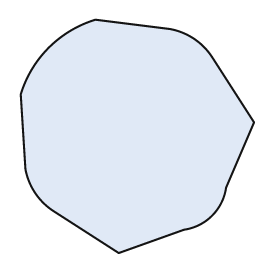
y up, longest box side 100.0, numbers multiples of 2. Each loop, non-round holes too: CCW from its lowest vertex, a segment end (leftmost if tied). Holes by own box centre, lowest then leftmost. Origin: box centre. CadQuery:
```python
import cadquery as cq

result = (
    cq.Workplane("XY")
    .moveTo(-8.0, -50.0)
    .lineTo(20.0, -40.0)
    .threePointArc((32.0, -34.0), (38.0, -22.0))
    .lineTo(50.0, 6.0)
    .lineTo(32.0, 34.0)
    .threePointArc((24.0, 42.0), (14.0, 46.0))
    .lineTo(-18.0, 50.0)
    .threePointArc((-38.0, 38.0), (-50.0, 18.0))
    .lineTo(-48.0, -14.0)
    .threePointArc((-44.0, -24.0), (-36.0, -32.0))
    .close()
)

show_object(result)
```